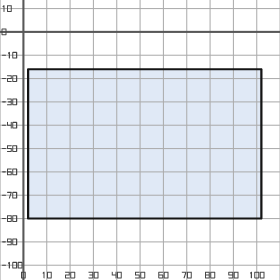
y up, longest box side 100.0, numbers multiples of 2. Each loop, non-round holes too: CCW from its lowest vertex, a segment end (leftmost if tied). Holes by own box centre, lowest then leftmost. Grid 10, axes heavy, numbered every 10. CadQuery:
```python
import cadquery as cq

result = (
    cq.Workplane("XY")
    .moveTo(2.0, -80.0)
    .lineTo(102.0, -80.0)
    .lineTo(102.0, -16.0)
    .lineTo(2.0, -16.0)
    .close()
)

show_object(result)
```